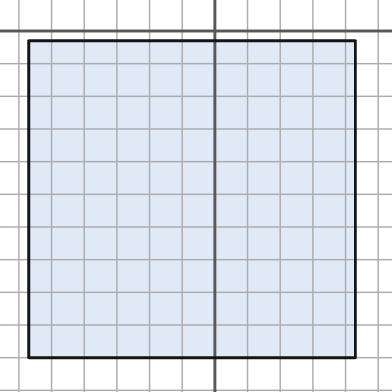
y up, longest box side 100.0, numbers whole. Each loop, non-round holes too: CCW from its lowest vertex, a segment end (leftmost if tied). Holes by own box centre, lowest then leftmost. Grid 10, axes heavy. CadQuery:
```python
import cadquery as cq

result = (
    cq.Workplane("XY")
    .moveTo(-57.0, -100.0)
    .lineTo(43.0, -100.0)
    .lineTo(43.0, -3.0)
    .lineTo(-57.0, -3.0)
    .close()
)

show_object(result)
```